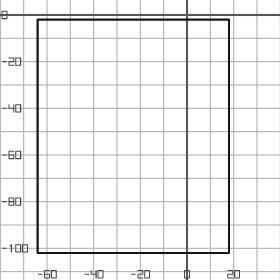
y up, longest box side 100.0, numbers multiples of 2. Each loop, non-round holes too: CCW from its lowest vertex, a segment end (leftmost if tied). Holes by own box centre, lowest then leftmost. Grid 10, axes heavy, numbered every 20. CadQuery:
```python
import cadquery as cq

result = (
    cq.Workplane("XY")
    .moveTo(-64.0, -102.0)
    .lineTo(18.0, -102.0)
    .lineTo(18.0, -2.0)
    .lineTo(-64.0, -2.0)
    .close()
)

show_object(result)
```